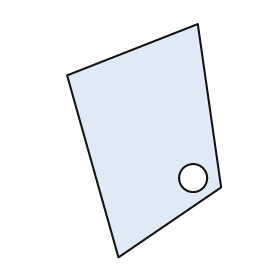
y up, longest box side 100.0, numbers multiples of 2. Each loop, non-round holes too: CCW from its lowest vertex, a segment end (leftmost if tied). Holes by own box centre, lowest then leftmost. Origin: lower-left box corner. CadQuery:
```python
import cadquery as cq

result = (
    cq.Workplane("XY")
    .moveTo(22.0, 0.0)
    .lineTo(66.0, 30.0)
    .lineTo(56.0, 100.0)
    .lineTo(0.0, 78.0)
    .close()
    .moveTo(54.0, 34.0)
    .circle(6.0)
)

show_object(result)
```